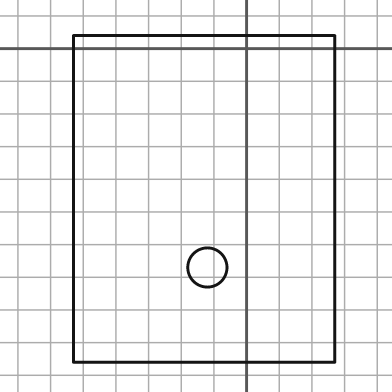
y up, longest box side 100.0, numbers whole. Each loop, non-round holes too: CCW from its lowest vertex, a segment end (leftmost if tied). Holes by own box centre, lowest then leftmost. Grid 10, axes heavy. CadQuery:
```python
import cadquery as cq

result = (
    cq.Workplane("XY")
    .moveTo(-53.0, -96.0)
    .lineTo(27.0, -96.0)
    .lineTo(27.0, 4.0)
    .lineTo(-53.0, 4.0)
    .close()
    .moveTo(-12.0, -67.0)
    .circle(6.0)
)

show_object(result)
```